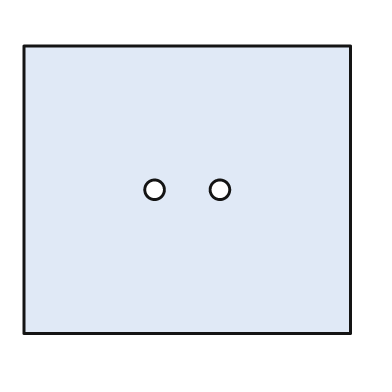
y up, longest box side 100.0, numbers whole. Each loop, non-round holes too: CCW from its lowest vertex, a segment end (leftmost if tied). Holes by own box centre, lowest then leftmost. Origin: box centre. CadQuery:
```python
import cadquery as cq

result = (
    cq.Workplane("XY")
    .moveTo(-50.0, -44.0)
    .lineTo(50.0, -44.0)
    .lineTo(50.0, 44.0)
    .lineTo(-50.0, 44.0)
    .close()
    .moveTo(-10.0, 0.0)
    .circle(3.0)
    .moveTo(10.0, 0.0)
    .circle(3.0)
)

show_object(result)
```